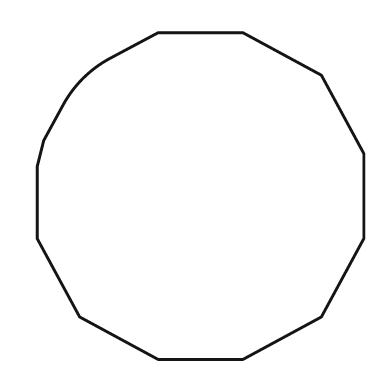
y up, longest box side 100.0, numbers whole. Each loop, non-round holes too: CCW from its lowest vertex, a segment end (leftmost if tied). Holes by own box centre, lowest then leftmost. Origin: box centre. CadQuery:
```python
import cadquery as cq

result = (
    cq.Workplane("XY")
    .moveTo(-13.0, -50.0)
    .lineTo(13.0, -50.0)
    .lineTo(37.0, -37.0)
    .lineTo(50.0, -13.0)
    .lineTo(50.0, 13.0)
    .lineTo(37.0, 37.0)
    .lineTo(13.0, 50.0)
    .lineTo(-13.0, 50.0)
    .lineTo(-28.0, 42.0)
    .threePointArc((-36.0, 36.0), (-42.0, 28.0))
    .lineTo(-48.0, 17.0)
    .lineTo(-50.0, 9.0)
    .lineTo(-50.0, -13.0)
    .lineTo(-37.0, -37.0)
    .close()
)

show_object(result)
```